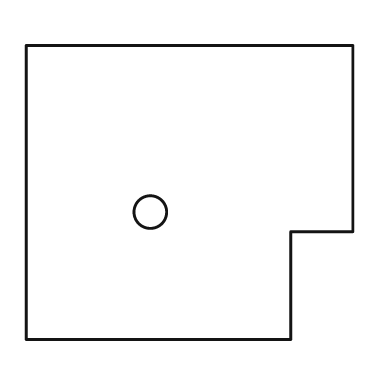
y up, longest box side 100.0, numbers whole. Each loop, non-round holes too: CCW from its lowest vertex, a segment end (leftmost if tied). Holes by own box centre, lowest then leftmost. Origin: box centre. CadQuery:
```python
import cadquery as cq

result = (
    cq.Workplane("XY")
    .moveTo(-50.0, -45.0)
    .lineTo(31.0, -45.0)
    .lineTo(31.0, -12.0)
    .lineTo(50.0, -12.0)
    .lineTo(50.0, 45.0)
    .lineTo(-50.0, 45.0)
    .close()
    .moveTo(-12.0, -6.0)
    .circle(5.0)
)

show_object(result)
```